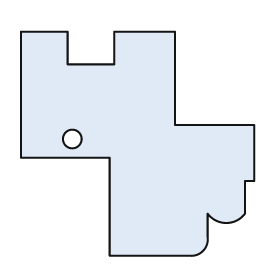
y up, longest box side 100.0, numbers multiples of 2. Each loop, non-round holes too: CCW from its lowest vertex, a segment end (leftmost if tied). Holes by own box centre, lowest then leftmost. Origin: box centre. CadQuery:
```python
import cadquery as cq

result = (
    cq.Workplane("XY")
    .moveTo(-12.0, -48.0)
    .lineTo(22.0, -48.0)
    .threePointArc((28.0, -46.0), (30.0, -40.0))
    .lineTo(30.0, -30.0)
    .threePointArc((38.0, -34.0), (46.0, -30.0))
    .lineTo(46.0, -16.0)
    .lineTo(50.0, -16.0)
    .lineTo(50.0, 8.0)
    .lineTo(16.0, 8.0)
    .lineTo(16.0, 48.0)
    .lineTo(-10.0, 48.0)
    .lineTo(-10.0, 34.0)
    .lineTo(-30.0, 34.0)
    .lineTo(-30.0, 48.0)
    .lineTo(-50.0, 48.0)
    .lineTo(-50.0, -6.0)
    .lineTo(-12.0, -6.0)
    .close()
    .moveTo(-28.0, 2.0)
    .circle(4.0)
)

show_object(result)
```